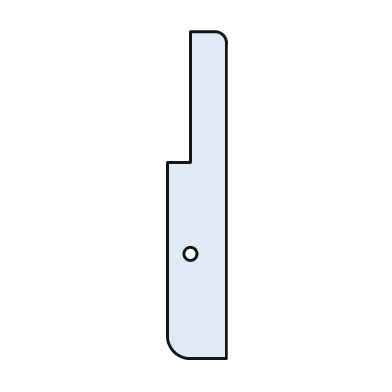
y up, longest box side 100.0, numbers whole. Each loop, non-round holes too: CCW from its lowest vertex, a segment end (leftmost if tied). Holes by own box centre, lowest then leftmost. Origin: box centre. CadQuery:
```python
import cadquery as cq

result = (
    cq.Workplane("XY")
    .moveTo(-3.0, -50.0)
    .lineTo(9.0, -50.0)
    .lineTo(9.0, 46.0)
    .threePointArc((8.0, 49.0), (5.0, 50.0))
    .lineTo(-2.0, 50.0)
    .lineTo(-2.0, 10.0)
    .lineTo(-9.0, 10.0)
    .lineTo(-9.0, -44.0)
    .threePointArc((-7.0, -48.0), (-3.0, -50.0))
    .close()
    .moveTo(-2.0, -18.0)
    .circle(2.0)
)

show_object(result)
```